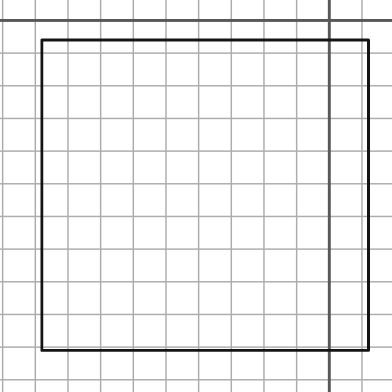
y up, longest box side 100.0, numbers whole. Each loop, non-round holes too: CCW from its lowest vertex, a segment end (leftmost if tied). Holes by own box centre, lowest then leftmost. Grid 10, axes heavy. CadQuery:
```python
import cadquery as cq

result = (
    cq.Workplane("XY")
    .moveTo(-88.0, -101.0)
    .lineTo(12.0, -101.0)
    .lineTo(12.0, -6.0)
    .lineTo(-88.0, -6.0)
    .close()
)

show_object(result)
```